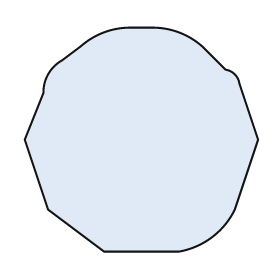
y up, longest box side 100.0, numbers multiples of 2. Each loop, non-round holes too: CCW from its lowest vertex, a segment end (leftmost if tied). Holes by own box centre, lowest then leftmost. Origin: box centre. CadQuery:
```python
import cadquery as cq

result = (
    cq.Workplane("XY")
    .moveTo(-16.0, -48.0)
    .lineTo(16.0, -48.0)
    .threePointArc((30.0, -42.0), (40.0, -30.0))
    .lineTo(50.0, 0.0)
    .lineTo(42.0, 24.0)
    .threePointArc((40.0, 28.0), (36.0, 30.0))
    .lineTo(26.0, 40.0)
    .threePointArc((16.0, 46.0), (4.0, 48.0))
    .lineTo(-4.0, 48.0)
    .threePointArc((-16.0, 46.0), (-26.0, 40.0))
    .lineTo(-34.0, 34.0)
    .threePointArc((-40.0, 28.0), (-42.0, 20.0))
    .lineTo(-50.0, 0.0)
    .lineTo(-40.0, -30.0)
    .close()
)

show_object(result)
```